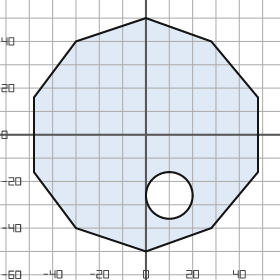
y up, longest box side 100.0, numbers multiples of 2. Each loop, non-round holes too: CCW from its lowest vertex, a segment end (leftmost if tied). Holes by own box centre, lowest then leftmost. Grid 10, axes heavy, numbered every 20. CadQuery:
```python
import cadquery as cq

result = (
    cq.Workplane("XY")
    .moveTo(0.0, -50.0)
    .lineTo(28.0, -40.0)
    .lineTo(48.0, -16.0)
    .lineTo(48.0, 16.0)
    .lineTo(28.0, 40.0)
    .lineTo(0.0, 50.0)
    .lineTo(-30.0, 40.0)
    .lineTo(-48.0, 16.0)
    .lineTo(-48.0, -16.0)
    .lineTo(-30.0, -40.0)
    .close()
    .moveTo(10.0, -26.0)
    .circle(10.0)
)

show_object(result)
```